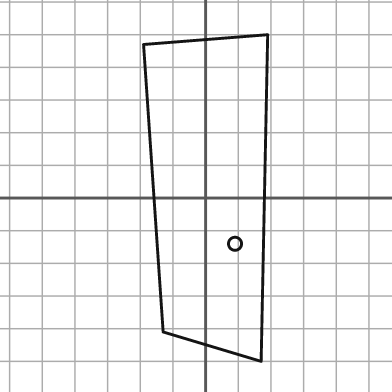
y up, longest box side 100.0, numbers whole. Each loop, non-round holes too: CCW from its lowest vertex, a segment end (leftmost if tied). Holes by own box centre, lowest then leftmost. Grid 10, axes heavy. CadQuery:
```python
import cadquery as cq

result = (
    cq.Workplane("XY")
    .moveTo(17.0, -50.0)
    .lineTo(19.0, 50.0)
    .lineTo(-19.0, 47.0)
    .lineTo(-13.0, -41.0)
    .close()
    .moveTo(9.0, -14.0)
    .circle(2.0)
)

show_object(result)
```